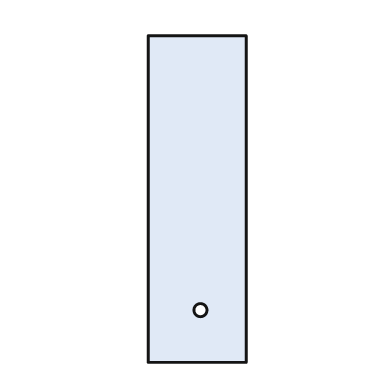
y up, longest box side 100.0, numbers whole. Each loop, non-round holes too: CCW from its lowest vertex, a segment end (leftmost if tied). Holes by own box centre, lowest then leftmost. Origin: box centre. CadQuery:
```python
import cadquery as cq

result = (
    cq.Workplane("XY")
    .moveTo(-15.0, -50.0)
    .lineTo(15.0, -50.0)
    .lineTo(15.0, 50.0)
    .lineTo(-15.0, 50.0)
    .close()
    .moveTo(1.0, -34.0)
    .circle(2.0)
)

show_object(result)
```